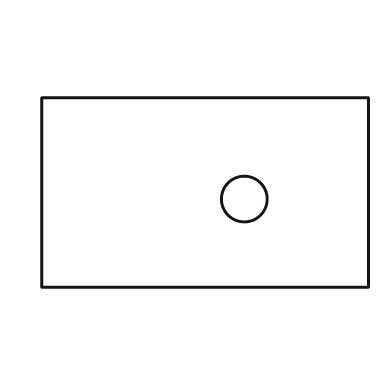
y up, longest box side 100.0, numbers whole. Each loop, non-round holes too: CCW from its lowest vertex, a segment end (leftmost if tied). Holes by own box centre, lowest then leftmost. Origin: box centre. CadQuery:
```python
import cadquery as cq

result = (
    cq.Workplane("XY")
    .moveTo(-50.0, -29.0)
    .lineTo(50.0, -29.0)
    .lineTo(50.0, 29.0)
    .lineTo(-50.0, 29.0)
    .close()
    .moveTo(12.0, -2.0)
    .circle(7.0)
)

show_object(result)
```